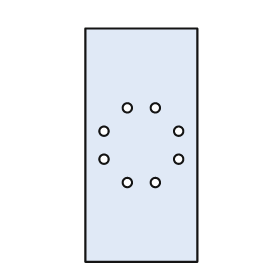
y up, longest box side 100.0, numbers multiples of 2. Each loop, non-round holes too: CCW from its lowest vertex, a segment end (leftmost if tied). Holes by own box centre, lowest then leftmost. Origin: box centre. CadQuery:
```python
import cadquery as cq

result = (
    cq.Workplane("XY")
    .moveTo(-24.0, -50.0)
    .lineTo(24.0, -50.0)
    .lineTo(24.0, 50.0)
    .lineTo(-24.0, 50.0)
    .close()
    .moveTo(-6.0, -16.0)
    .circle(2.0)
    .moveTo(6.0, -16.0)
    .circle(2.0)
    .moveTo(-16.0, -6.0)
    .circle(2.0)
    .moveTo(16.0, -6.0)
    .circle(2.0)
    .moveTo(-16.0, 6.0)
    .circle(2.0)
    .moveTo(16.0, 6.0)
    .circle(2.0)
    .moveTo(-6.0, 16.0)
    .circle(2.0)
    .moveTo(6.0, 16.0)
    .circle(2.0)
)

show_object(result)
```